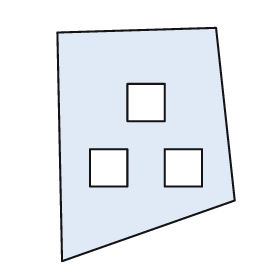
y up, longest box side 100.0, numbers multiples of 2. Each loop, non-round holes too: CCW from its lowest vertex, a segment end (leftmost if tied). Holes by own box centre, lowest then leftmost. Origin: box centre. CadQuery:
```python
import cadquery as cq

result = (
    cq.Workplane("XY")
    .moveTo(-36.0, -50.0)
    .lineTo(38.0, -24.0)
    .lineTo(30.0, 50.0)
    .lineTo(-38.0, 48.0)
    .close()
    .moveTo(-24.0, -18.0)
    .lineTo(-8.0, -18.0)
    .lineTo(-8.0, -2.0)
    .lineTo(-24.0, -2.0)
    .close()
    .moveTo(8.0, -18.0)
    .lineTo(24.0, -18.0)
    .lineTo(24.0, -2.0)
    .lineTo(8.0, -2.0)
    .close()
    .moveTo(-8.0, 10.0)
    .lineTo(8.0, 10.0)
    .lineTo(8.0, 26.0)
    .lineTo(-8.0, 26.0)
    .close()
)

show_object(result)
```